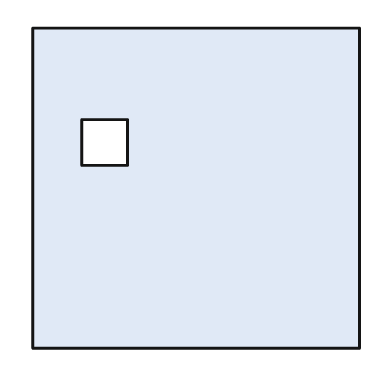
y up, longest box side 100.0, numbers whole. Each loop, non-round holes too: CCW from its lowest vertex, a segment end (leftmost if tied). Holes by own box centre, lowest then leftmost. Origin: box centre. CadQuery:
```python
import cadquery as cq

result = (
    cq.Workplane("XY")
    .moveTo(-50.0, -49.0)
    .lineTo(50.0, -49.0)
    .lineTo(50.0, 49.0)
    .lineTo(-50.0, 49.0)
    .close()
    .moveTo(-35.0, 7.0)
    .lineTo(-21.0, 7.0)
    .lineTo(-21.0, 21.0)
    .lineTo(-35.0, 21.0)
    .close()
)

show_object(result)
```